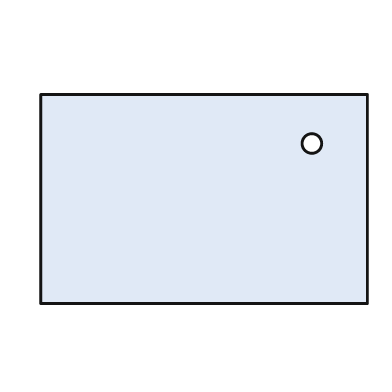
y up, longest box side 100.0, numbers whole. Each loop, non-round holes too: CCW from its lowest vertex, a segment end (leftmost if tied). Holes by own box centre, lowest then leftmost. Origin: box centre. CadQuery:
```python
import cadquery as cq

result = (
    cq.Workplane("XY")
    .moveTo(-50.0, -32.0)
    .lineTo(50.0, -32.0)
    .lineTo(50.0, 32.0)
    .lineTo(-50.0, 32.0)
    .close()
    .moveTo(33.0, 17.0)
    .circle(3.0)
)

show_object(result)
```